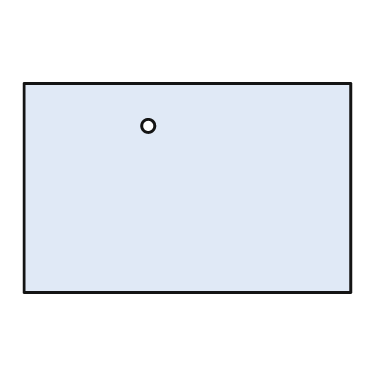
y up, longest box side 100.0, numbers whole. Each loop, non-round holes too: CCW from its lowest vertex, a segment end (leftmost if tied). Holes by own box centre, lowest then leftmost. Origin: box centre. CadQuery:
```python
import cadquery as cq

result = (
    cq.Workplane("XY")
    .moveTo(-50.0, -32.0)
    .lineTo(50.0, -32.0)
    .lineTo(50.0, 32.0)
    .lineTo(-50.0, 32.0)
    .close()
    .moveTo(-12.0, 19.0)
    .circle(2.0)
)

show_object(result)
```